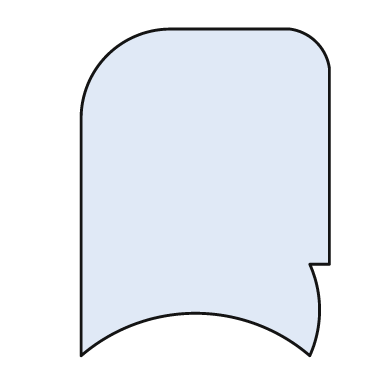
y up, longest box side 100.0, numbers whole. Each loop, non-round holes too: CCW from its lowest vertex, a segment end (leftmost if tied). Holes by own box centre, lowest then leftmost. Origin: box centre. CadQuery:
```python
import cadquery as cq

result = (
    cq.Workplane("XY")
    .moveTo(-38.0, -50.0)
    .threePointArc((-3.0, -37.0), (32.0, -50.0))
    .threePointArc((35.0, -36.0), (32.0, -22.0))
    .lineTo(38.0, -22.0)
    .lineTo(38.0, 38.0)
    .threePointArc((34.0, 46.0), (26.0, 50.0))
    .lineTo(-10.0, 50.0)
    .threePointArc((-30.0, 42.0), (-38.0, 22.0))
    .close()
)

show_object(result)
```